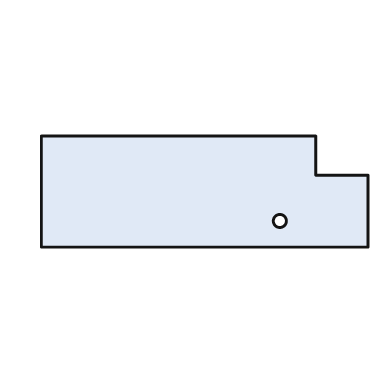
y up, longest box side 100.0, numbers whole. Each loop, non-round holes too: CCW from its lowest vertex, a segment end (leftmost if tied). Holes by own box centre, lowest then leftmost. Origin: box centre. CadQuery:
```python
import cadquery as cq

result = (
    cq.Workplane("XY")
    .moveTo(-50.0, -17.0)
    .lineTo(50.0, -17.0)
    .lineTo(50.0, 5.0)
    .lineTo(34.0, 5.0)
    .lineTo(34.0, 17.0)
    .lineTo(-50.0, 17.0)
    .close()
    .moveTo(23.0, -9.0)
    .circle(2.0)
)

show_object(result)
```